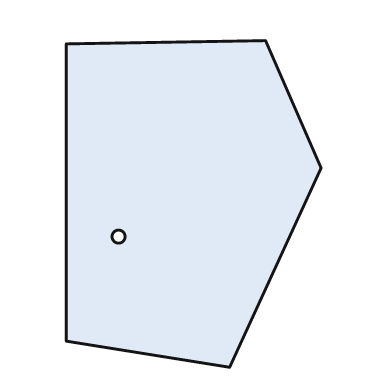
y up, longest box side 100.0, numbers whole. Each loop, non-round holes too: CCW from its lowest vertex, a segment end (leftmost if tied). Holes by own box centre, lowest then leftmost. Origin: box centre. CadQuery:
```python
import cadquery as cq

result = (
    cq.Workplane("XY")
    .moveTo(11.0, -50.0)
    .lineTo(39.0, 11.0)
    .lineTo(22.0, 50.0)
    .lineTo(-39.0, 49.0)
    .lineTo(-39.0, -42.0)
    .close()
    .moveTo(-23.0, -10.0)
    .circle(2.0)
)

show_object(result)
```